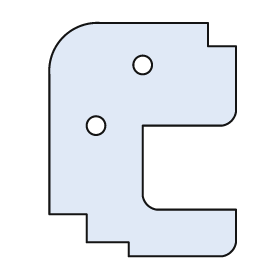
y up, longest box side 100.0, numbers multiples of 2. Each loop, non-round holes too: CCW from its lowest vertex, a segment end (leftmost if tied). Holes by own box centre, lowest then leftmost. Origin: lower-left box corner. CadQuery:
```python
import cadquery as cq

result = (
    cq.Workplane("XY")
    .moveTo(34.0, 0.0)
    .lineTo(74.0, 0.0)
    .threePointArc((78.0, 2.0), (80.0, 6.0))
    .lineTo(80.0, 20.0)
    .lineTo(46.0, 20.0)
    .threePointArc((42.0, 22.0), (40.0, 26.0))
    .lineTo(40.0, 56.0)
    .lineTo(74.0, 56.0)
    .threePointArc((78.0, 58.0), (80.0, 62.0))
    .lineTo(80.0, 90.0)
    .lineTo(68.0, 90.0)
    .lineTo(68.0, 100.0)
    .lineTo(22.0, 100.0)
    .threePointArc((6.0, 94.0), (0.0, 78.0))
    .lineTo(0.0, 18.0)
    .lineTo(16.0, 18.0)
    .lineTo(16.0, 6.0)
    .lineTo(34.0, 6.0)
    .close()
    .moveTo(20.0, 56.0)
    .circle(4.0)
    .moveTo(40.0, 82.0)
    .circle(4.0)
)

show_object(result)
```